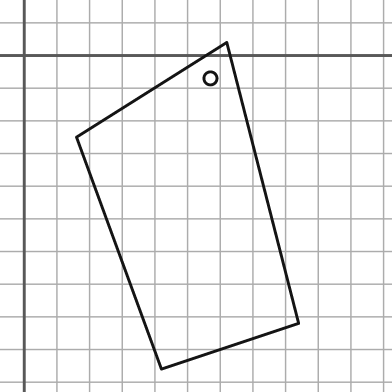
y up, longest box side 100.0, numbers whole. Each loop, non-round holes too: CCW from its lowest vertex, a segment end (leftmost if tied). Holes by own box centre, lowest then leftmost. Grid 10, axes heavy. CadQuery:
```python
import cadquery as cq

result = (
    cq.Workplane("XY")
    .moveTo(42.0, -96.0)
    .lineTo(84.0, -82.0)
    .lineTo(62.0, 4.0)
    .lineTo(16.0, -25.0)
    .close()
    .moveTo(57.0, -7.0)
    .circle(2.0)
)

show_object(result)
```